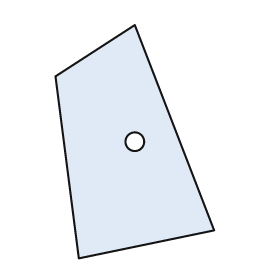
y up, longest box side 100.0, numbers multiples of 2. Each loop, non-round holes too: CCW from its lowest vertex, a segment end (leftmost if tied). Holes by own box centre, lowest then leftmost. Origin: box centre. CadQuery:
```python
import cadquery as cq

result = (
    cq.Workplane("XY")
    .moveTo(-24.0, -50.0)
    .lineTo(34.0, -38.0)
    .lineTo(0.0, 50.0)
    .lineTo(-34.0, 28.0)
    .close()
    .moveTo(0.0, 0.0)
    .circle(4.0)
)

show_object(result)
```